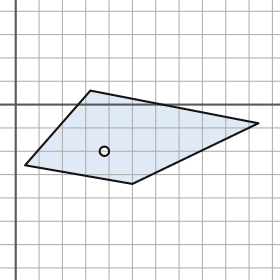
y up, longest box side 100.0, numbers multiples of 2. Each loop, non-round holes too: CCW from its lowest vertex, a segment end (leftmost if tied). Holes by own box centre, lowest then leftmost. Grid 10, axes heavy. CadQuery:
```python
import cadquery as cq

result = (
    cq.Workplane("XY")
    .moveTo(50.0, -34.0)
    .lineTo(104.0, -8.0)
    .lineTo(32.0, 6.0)
    .lineTo(4.0, -26.0)
    .close()
    .moveTo(38.0, -20.0)
    .circle(2.0)
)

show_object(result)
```